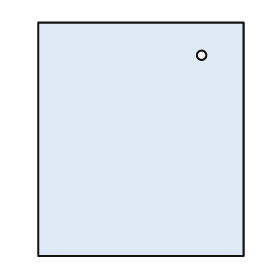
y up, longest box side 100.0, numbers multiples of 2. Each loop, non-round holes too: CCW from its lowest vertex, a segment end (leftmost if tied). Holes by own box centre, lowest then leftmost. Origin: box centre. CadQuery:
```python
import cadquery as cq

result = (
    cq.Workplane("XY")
    .moveTo(-44.0, -50.0)
    .lineTo(44.0, -50.0)
    .lineTo(44.0, 50.0)
    .lineTo(-44.0, 50.0)
    .close()
    .moveTo(26.0, 36.0)
    .circle(2.0)
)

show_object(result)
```